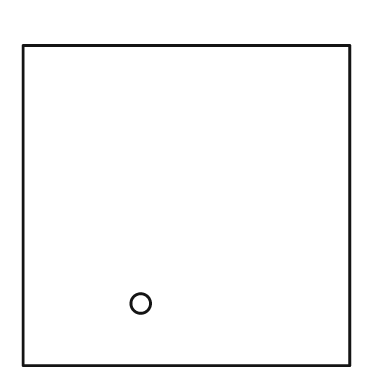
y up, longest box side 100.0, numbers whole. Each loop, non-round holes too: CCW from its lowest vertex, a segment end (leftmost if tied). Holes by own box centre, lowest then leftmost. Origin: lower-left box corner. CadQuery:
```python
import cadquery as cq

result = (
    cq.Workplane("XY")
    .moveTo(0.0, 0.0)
    .lineTo(100.0, 0.0)
    .lineTo(100.0, 98.0)
    .lineTo(0.0, 98.0)
    .close()
    .moveTo(36.0, 19.0)
    .circle(3.0)
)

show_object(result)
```